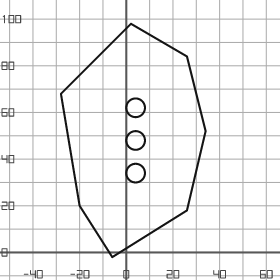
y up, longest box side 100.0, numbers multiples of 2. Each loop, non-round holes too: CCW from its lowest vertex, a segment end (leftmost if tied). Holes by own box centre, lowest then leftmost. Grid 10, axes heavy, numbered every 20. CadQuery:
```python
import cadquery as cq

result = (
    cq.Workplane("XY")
    .moveTo(-6.0, -2.0)
    .lineTo(26.0, 18.0)
    .lineTo(34.0, 52.0)
    .lineTo(26.0, 84.0)
    .lineTo(2.0, 98.0)
    .lineTo(-28.0, 68.0)
    .lineTo(-20.0, 20.0)
    .close()
    .moveTo(4.0, 34.0)
    .circle(4.0)
    .moveTo(4.0, 48.0)
    .circle(4.0)
    .moveTo(4.0, 62.0)
    .circle(4.0)
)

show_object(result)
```